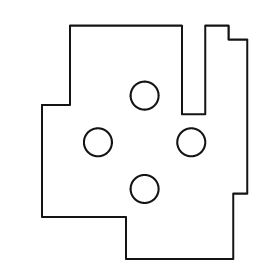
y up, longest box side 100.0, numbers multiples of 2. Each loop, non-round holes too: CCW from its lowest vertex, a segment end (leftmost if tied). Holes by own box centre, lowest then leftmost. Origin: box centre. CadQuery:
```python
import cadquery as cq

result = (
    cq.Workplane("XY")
    .moveTo(-8.0, -50.0)
    .lineTo(38.0, -50.0)
    .lineTo(38.0, -22.0)
    .lineTo(44.0, -22.0)
    .lineTo(44.0, 44.0)
    .lineTo(36.0, 44.0)
    .lineTo(36.0, 50.0)
    .lineTo(26.0, 50.0)
    .lineTo(26.0, 12.0)
    .lineTo(16.0, 12.0)
    .lineTo(16.0, 50.0)
    .lineTo(-32.0, 50.0)
    .lineTo(-32.0, 16.0)
    .lineTo(-44.0, 16.0)
    .lineTo(-44.0, -32.0)
    .lineTo(-8.0, -32.0)
    .close()
    .moveTo(0.0, -20.0)
    .circle(6.0)
    .moveTo(-20.0, 0.0)
    .circle(6.0)
    .moveTo(20.0, 0.0)
    .circle(6.0)
    .moveTo(0.0, 20.0)
    .circle(6.0)
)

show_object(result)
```